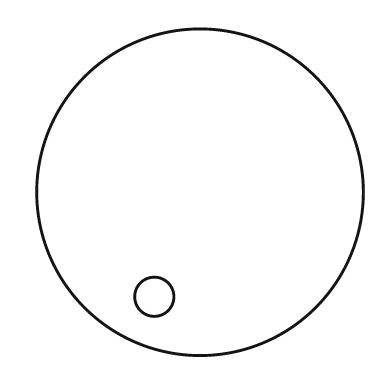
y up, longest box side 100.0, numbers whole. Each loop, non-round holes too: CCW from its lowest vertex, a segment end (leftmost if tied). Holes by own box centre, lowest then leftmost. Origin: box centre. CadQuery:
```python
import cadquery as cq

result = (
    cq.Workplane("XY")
    .moveTo(0.0, 0.0)
    .circle(50.0)
    .moveTo(-14.0, -32.0)
    .circle(6.0)
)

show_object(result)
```